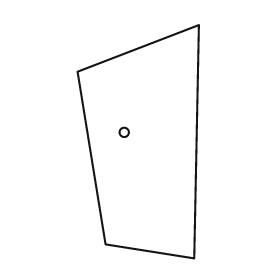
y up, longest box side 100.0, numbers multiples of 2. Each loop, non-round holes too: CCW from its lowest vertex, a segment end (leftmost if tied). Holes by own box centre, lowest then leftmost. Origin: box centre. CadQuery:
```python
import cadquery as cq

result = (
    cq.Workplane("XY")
    .moveTo(24.0, -50.0)
    .lineTo(26.0, 50.0)
    .lineTo(-26.0, 30.0)
    .lineTo(-14.0, -44.0)
    .close()
    .moveTo(-6.0, 4.0)
    .circle(2.0)
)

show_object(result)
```